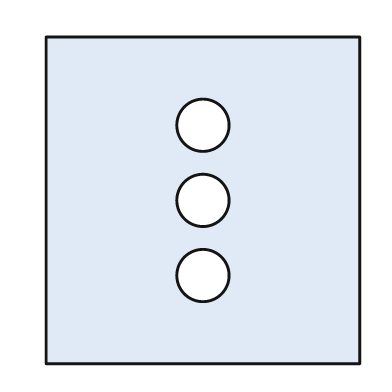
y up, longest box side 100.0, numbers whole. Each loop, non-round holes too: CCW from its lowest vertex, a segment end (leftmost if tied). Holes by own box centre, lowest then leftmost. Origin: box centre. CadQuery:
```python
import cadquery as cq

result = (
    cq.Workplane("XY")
    .moveTo(-48.0, -50.0)
    .lineTo(48.0, -50.0)
    .lineTo(48.0, 50.0)
    .lineTo(-48.0, 50.0)
    .close()
    .moveTo(0.0, -23.0)
    .circle(8.0)
    .moveTo(0.0, 0.0)
    .circle(8.0)
    .moveTo(0.0, 23.0)
    .circle(8.0)
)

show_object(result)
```